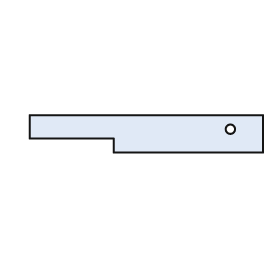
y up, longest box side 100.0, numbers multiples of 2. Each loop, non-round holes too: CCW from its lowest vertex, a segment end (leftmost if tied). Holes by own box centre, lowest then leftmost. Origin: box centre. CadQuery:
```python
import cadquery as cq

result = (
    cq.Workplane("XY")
    .moveTo(-14.0, -8.0)
    .lineTo(50.0, -8.0)
    .lineTo(50.0, 8.0)
    .lineTo(-50.0, 8.0)
    .lineTo(-50.0, -2.0)
    .lineTo(-14.0, -2.0)
    .close()
    .moveTo(36.0, 2.0)
    .circle(2.0)
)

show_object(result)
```